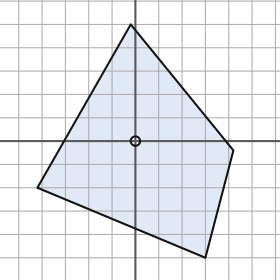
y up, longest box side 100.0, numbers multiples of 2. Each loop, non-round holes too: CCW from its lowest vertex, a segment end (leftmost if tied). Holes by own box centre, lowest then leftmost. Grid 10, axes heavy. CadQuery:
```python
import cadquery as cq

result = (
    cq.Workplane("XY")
    .moveTo(30.0, -50.0)
    .lineTo(42.0, -4.0)
    .lineTo(-2.0, 50.0)
    .lineTo(-42.0, -20.0)
    .close()
    .moveTo(0.0, 0.0)
    .circle(2.0)
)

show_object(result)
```